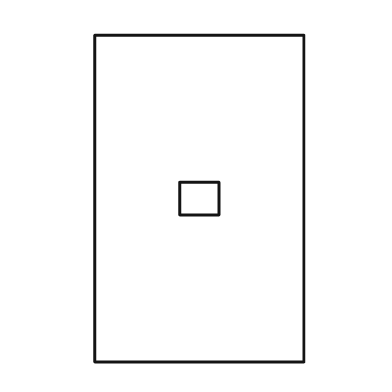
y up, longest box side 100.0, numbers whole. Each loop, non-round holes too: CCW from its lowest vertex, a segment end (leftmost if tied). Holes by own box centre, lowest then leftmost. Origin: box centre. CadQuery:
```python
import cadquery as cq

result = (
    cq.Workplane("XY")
    .moveTo(-32.0, -50.0)
    .lineTo(32.0, -50.0)
    .lineTo(32.0, 50.0)
    .lineTo(-32.0, 50.0)
    .close()
    .moveTo(-6.0, -5.0)
    .lineTo(6.0, -5.0)
    .lineTo(6.0, 5.0)
    .lineTo(-6.0, 5.0)
    .close()
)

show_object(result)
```